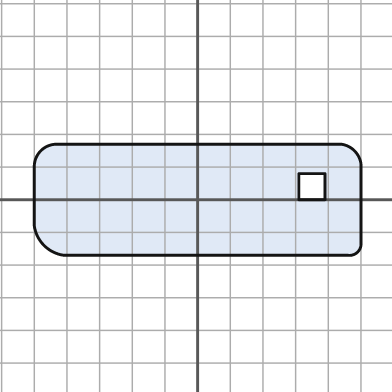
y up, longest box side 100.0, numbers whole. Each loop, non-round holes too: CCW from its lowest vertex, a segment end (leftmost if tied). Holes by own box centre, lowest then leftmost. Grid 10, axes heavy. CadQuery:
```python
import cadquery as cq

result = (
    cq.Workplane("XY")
    .moveTo(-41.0, -17.0)
    .lineTo(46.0, -17.0)
    .threePointArc((49.0, -16.0), (50.0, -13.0))
    .lineTo(50.0, 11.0)
    .threePointArc((48.0, 15.0), (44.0, 17.0))
    .lineTo(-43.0, 17.0)
    .threePointArc((-48.0, 15.0), (-50.0, 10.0))
    .lineTo(-50.0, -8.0)
    .threePointArc((-47.0, -14.0), (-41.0, -17.0))
    .close()
    .moveTo(31.0, 0.0)
    .lineTo(39.0, 0.0)
    .lineTo(39.0, 8.0)
    .lineTo(31.0, 8.0)
    .close()
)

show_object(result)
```